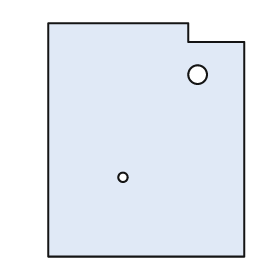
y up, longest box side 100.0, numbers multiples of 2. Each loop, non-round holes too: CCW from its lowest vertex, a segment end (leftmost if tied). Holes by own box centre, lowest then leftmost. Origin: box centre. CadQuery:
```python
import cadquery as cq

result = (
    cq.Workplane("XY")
    .moveTo(-42.0, -50.0)
    .lineTo(42.0, -50.0)
    .lineTo(42.0, 42.0)
    .lineTo(18.0, 42.0)
    .lineTo(18.0, 50.0)
    .lineTo(-42.0, 50.0)
    .close()
    .moveTo(-10.0, -16.0)
    .circle(2.0)
    .moveTo(22.0, 28.0)
    .circle(4.0)
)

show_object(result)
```